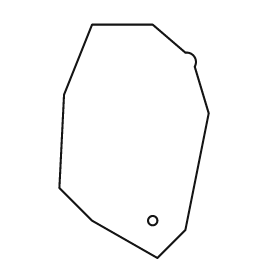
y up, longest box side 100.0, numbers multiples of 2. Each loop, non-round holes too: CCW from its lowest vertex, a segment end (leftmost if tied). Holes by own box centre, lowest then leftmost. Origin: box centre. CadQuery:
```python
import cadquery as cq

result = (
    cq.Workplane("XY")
    .moveTo(10.0, -50.0)
    .lineTo(22.0, -38.0)
    .lineTo(32.0, 12.0)
    .lineTo(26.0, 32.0)
    .threePointArc((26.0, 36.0), (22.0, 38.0))
    .lineTo(8.0, 50.0)
    .lineTo(-18.0, 50.0)
    .lineTo(-30.0, 20.0)
    .lineTo(-32.0, -20.0)
    .lineTo(-18.0, -34.0)
    .close()
    .moveTo(8.0, -34.0)
    .circle(2.0)
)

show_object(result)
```